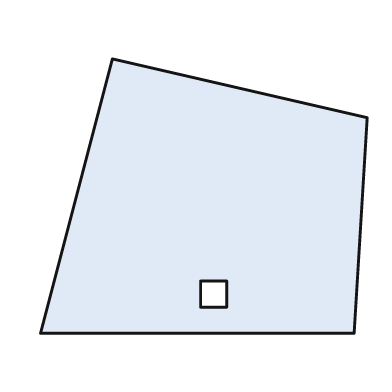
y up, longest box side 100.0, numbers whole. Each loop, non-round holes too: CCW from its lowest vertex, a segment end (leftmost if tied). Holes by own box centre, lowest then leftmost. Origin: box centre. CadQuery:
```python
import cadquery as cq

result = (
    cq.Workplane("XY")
    .moveTo(-50.0, -42.0)
    .lineTo(46.0, -42.0)
    .lineTo(50.0, 24.0)
    .lineTo(-28.0, 42.0)
    .close()
    .moveTo(-1.0, -34.0)
    .lineTo(7.0, -34.0)
    .lineTo(7.0, -26.0)
    .lineTo(-1.0, -26.0)
    .close()
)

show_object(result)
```